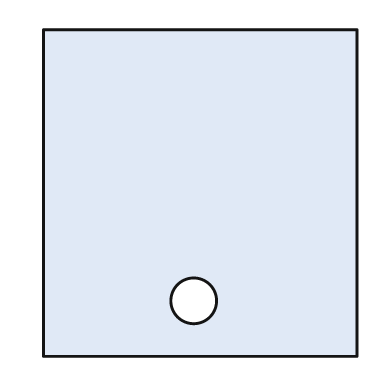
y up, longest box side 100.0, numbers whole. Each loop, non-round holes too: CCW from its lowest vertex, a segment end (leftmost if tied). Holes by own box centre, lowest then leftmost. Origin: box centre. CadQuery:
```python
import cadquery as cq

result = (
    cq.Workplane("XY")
    .moveTo(-48.0, -50.0)
    .lineTo(48.0, -50.0)
    .lineTo(48.0, 50.0)
    .lineTo(-48.0, 50.0)
    .close()
    .moveTo(-2.0, -33.0)
    .circle(7.0)
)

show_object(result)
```